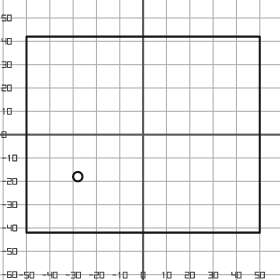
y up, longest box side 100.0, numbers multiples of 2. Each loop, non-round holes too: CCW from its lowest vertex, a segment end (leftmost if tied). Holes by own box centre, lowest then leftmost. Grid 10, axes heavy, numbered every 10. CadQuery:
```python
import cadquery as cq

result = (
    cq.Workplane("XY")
    .moveTo(-50.0, -42.0)
    .lineTo(50.0, -42.0)
    .lineTo(50.0, 42.0)
    .lineTo(-50.0, 42.0)
    .close()
    .moveTo(-28.0, -18.0)
    .circle(2.0)
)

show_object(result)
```